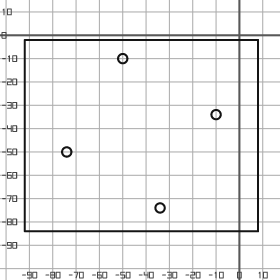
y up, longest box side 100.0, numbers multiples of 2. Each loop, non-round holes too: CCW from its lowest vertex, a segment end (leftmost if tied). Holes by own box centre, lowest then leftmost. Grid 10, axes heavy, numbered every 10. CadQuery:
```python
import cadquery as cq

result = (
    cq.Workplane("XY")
    .moveTo(-92.0, -84.0)
    .lineTo(8.0, -84.0)
    .lineTo(8.0, -2.0)
    .lineTo(-92.0, -2.0)
    .close()
    .moveTo(-34.0, -74.0)
    .circle(2.0)
    .moveTo(-74.0, -50.0)
    .circle(2.0)
    .moveTo(-10.0, -34.0)
    .circle(2.0)
    .moveTo(-50.0, -10.0)
    .circle(2.0)
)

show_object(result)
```